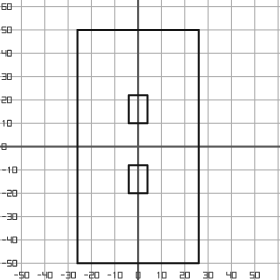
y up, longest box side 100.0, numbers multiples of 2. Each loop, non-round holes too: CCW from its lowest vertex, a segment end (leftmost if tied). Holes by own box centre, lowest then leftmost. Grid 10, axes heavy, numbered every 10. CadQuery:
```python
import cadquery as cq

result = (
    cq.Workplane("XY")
    .moveTo(-26.0, -50.0)
    .lineTo(26.0, -50.0)
    .lineTo(26.0, 50.0)
    .lineTo(-26.0, 50.0)
    .close()
    .moveTo(-4.0, -20.0)
    .lineTo(4.0, -20.0)
    .lineTo(4.0, -8.0)
    .lineTo(-4.0, -8.0)
    .close()
    .moveTo(-4.0, 10.0)
    .lineTo(4.0, 10.0)
    .lineTo(4.0, 22.0)
    .lineTo(-4.0, 22.0)
    .close()
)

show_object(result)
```